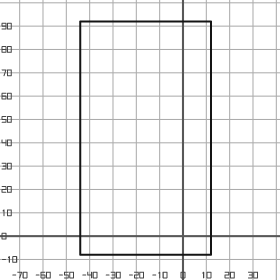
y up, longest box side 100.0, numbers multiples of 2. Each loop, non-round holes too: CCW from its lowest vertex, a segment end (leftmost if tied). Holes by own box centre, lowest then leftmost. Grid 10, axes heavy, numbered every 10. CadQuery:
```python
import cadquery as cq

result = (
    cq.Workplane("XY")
    .moveTo(-44.0, -8.0)
    .lineTo(12.0, -8.0)
    .lineTo(12.0, 92.0)
    .lineTo(-44.0, 92.0)
    .close()
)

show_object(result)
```